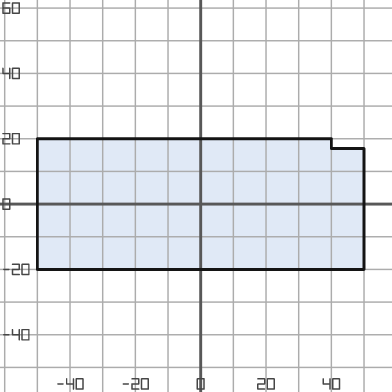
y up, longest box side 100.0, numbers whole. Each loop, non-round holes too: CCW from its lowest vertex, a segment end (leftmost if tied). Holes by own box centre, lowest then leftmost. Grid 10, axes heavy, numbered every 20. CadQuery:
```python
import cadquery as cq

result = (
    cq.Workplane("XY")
    .moveTo(-50.0, -20.0)
    .lineTo(50.0, -20.0)
    .lineTo(50.0, 17.0)
    .lineTo(40.0, 17.0)
    .lineTo(40.0, 20.0)
    .lineTo(-50.0, 20.0)
    .close()
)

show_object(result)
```